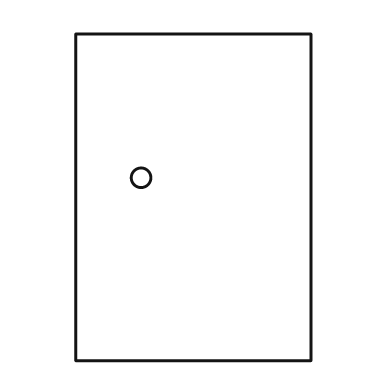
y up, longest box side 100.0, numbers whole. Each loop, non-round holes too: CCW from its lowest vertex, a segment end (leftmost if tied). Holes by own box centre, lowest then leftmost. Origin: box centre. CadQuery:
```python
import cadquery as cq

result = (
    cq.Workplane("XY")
    .moveTo(-36.0, -50.0)
    .lineTo(36.0, -50.0)
    .lineTo(36.0, 50.0)
    .lineTo(-36.0, 50.0)
    .close()
    .moveTo(-16.0, 6.0)
    .circle(3.0)
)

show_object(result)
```